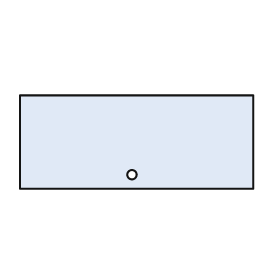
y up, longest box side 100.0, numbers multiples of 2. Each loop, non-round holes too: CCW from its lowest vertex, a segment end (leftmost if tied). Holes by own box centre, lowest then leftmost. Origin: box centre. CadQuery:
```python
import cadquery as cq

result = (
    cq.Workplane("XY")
    .moveTo(-50.0, -20.0)
    .lineTo(50.0, -20.0)
    .lineTo(50.0, 20.0)
    .lineTo(-50.0, 20.0)
    .close()
    .moveTo(-2.0, -14.0)
    .circle(2.0)
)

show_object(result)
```